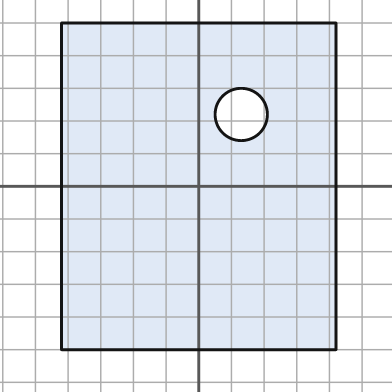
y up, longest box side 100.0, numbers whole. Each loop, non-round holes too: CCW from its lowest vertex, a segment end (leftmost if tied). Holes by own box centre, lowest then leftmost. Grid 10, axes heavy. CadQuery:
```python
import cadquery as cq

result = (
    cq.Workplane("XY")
    .moveTo(-42.0, -50.0)
    .lineTo(42.0, -50.0)
    .lineTo(42.0, 50.0)
    .lineTo(-42.0, 50.0)
    .close()
    .moveTo(13.0, 22.0)
    .circle(8.0)
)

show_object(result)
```